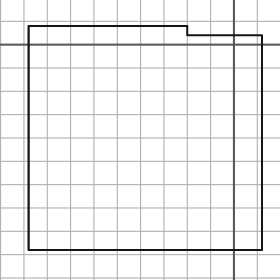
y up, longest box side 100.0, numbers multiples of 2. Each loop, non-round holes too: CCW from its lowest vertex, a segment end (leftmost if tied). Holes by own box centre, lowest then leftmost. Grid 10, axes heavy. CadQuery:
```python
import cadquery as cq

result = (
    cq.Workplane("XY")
    .moveTo(-88.0, -88.0)
    .lineTo(12.0, -88.0)
    .lineTo(12.0, 4.0)
    .lineTo(-20.0, 4.0)
    .lineTo(-20.0, 8.0)
    .lineTo(-88.0, 8.0)
    .close()
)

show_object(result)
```